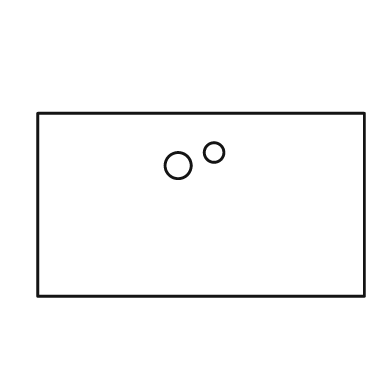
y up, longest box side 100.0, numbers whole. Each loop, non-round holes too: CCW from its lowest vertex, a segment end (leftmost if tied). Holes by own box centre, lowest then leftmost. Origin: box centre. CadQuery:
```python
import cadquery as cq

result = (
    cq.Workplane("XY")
    .moveTo(-50.0, -28.0)
    .lineTo(50.0, -28.0)
    .lineTo(50.0, 28.0)
    .lineTo(-50.0, 28.0)
    .close()
    .moveTo(-7.0, 12.0)
    .circle(4.0)
    .moveTo(4.0, 16.0)
    .circle(3.0)
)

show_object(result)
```